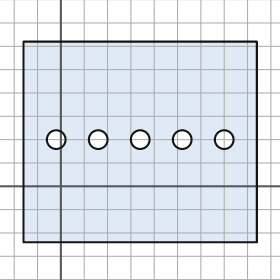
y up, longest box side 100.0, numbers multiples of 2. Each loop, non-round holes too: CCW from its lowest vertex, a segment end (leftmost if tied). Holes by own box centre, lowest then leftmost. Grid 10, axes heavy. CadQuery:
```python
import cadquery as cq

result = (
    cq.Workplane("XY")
    .moveTo(-16.0, -24.0)
    .lineTo(84.0, -24.0)
    .lineTo(84.0, 62.0)
    .lineTo(-16.0, 62.0)
    .close()
    .moveTo(-2.0, 20.0)
    .circle(4.0)
    .moveTo(16.0, 20.0)
    .circle(4.0)
    .moveTo(34.0, 20.0)
    .circle(4.0)
    .moveTo(52.0, 20.0)
    .circle(4.0)
    .moveTo(70.0, 20.0)
    .circle(4.0)
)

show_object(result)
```